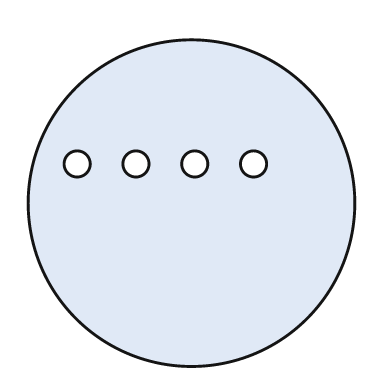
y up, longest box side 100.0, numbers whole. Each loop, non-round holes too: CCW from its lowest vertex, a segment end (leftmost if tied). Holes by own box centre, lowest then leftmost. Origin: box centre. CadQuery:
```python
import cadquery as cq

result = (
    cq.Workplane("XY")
    .moveTo(0.0, 0.0)
    .circle(50.0)
    .moveTo(-35.0, 12.0)
    .circle(4.0)
    .moveTo(-17.0, 12.0)
    .circle(4.0)
    .moveTo(1.0, 12.0)
    .circle(4.0)
    .moveTo(19.0, 12.0)
    .circle(4.0)
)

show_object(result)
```